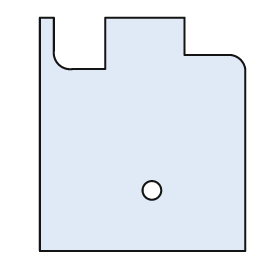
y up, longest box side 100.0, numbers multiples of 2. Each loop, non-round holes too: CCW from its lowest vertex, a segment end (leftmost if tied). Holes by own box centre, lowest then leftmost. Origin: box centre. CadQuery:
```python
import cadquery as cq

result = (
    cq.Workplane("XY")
    .moveTo(-44.0, -50.0)
    .lineTo(44.0, -50.0)
    .lineTo(44.0, 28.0)
    .threePointArc((42.0, 32.0), (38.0, 34.0))
    .lineTo(18.0, 34.0)
    .lineTo(18.0, 50.0)
    .lineTo(-16.0, 50.0)
    .lineTo(-16.0, 28.0)
    .lineTo(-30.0, 28.0)
    .threePointArc((-36.0, 30.0), (-38.0, 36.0))
    .lineTo(-38.0, 50.0)
    .lineTo(-44.0, 50.0)
    .close()
    .moveTo(4.0, -24.0)
    .circle(4.0)
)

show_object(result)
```